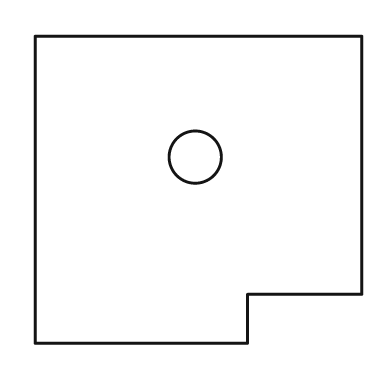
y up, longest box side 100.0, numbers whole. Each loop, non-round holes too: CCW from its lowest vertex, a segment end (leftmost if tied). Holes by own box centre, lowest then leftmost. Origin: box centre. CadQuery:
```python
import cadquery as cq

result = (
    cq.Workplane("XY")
    .moveTo(-50.0, -47.0)
    .lineTo(15.0, -47.0)
    .lineTo(15.0, -32.0)
    .lineTo(50.0, -32.0)
    .lineTo(50.0, 47.0)
    .lineTo(-50.0, 47.0)
    .close()
    .moveTo(-1.0, 10.0)
    .circle(8.0)
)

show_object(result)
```